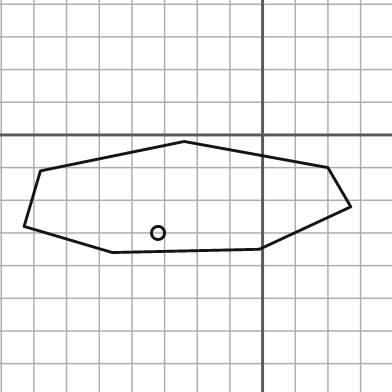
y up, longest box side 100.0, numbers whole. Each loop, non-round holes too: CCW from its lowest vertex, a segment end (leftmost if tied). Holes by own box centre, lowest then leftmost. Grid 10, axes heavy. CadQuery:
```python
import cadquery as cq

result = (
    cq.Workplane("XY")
    .moveTo(-46.0, -36.0)
    .lineTo(-1.0, -35.0)
    .lineTo(27.0, -22.0)
    .lineTo(20.0, -10.0)
    .lineTo(-24.0, -2.0)
    .lineTo(-68.0, -11.0)
    .lineTo(-73.0, -28.0)
    .close()
    .moveTo(-32.0, -30.0)
    .circle(2.0)
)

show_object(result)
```